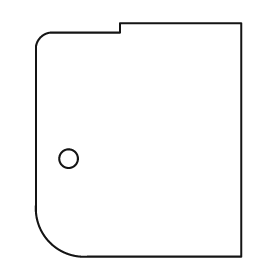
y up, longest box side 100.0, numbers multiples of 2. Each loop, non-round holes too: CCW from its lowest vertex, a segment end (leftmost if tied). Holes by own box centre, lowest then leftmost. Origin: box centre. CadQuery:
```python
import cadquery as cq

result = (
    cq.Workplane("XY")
    .moveTo(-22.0, -50.0)
    .lineTo(44.0, -50.0)
    .lineTo(44.0, 50.0)
    .lineTo(-8.0, 50.0)
    .lineTo(-8.0, 46.0)
    .lineTo(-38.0, 46.0)
    .threePointArc((-42.0, 44.0), (-44.0, 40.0))
    .lineTo(-44.0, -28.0)
    .threePointArc((-38.0, -44.0), (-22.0, -50.0))
    .close()
    .moveTo(-30.0, -8.0)
    .circle(4.0)
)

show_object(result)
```